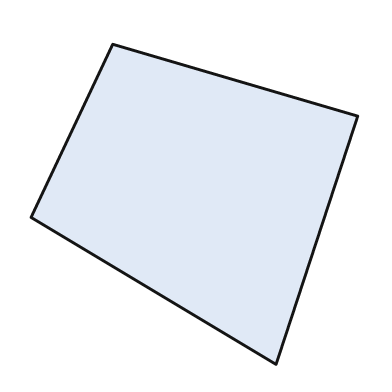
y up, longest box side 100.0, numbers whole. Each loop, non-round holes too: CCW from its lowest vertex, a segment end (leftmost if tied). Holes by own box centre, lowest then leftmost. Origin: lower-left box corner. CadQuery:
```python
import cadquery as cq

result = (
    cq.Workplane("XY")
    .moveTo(75.0, 0.0)
    .lineTo(100.0, 76.0)
    .lineTo(25.0, 98.0)
    .lineTo(0.0, 45.0)
    .close()
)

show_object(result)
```